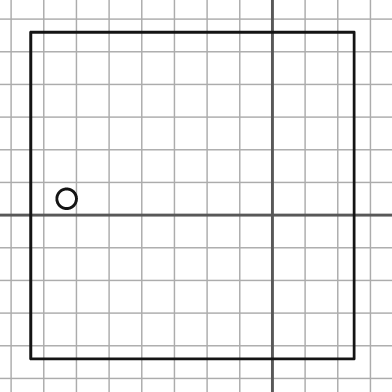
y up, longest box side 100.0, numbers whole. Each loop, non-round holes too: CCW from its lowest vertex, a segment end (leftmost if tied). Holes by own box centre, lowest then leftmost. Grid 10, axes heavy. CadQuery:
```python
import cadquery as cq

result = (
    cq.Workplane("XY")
    .moveTo(-74.0, -44.0)
    .lineTo(25.0, -44.0)
    .lineTo(25.0, 56.0)
    .lineTo(-74.0, 56.0)
    .close()
    .moveTo(-63.0, 5.0)
    .circle(3.0)
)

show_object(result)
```